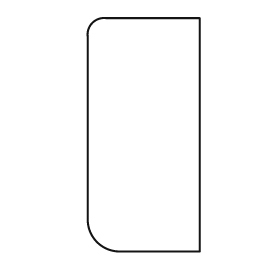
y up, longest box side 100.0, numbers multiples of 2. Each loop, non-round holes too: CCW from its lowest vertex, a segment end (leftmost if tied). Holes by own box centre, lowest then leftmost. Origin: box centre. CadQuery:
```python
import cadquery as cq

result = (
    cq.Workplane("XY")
    .moveTo(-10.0, -50.0)
    .lineTo(24.0, -50.0)
    .lineTo(24.0, 50.0)
    .lineTo(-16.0, 50.0)
    .threePointArc((-22.0, 48.0), (-24.0, 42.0))
    .lineTo(-24.0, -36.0)
    .threePointArc((-20.0, -46.0), (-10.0, -50.0))
    .close()
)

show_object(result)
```